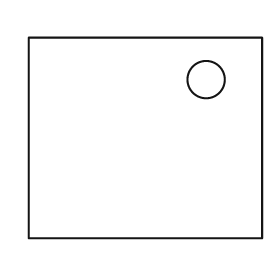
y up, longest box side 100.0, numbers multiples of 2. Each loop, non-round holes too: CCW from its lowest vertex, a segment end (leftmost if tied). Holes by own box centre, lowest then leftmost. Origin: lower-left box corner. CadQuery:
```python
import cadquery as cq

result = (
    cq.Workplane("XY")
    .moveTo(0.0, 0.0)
    .lineTo(100.0, 0.0)
    .lineTo(100.0, 86.0)
    .lineTo(0.0, 86.0)
    .close()
    .moveTo(76.0, 68.0)
    .circle(8.0)
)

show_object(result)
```